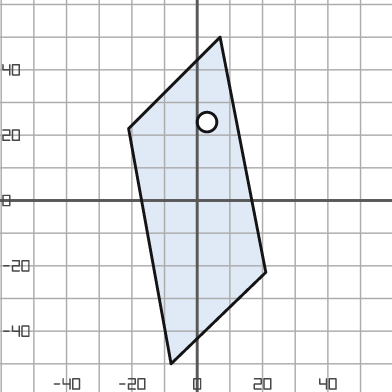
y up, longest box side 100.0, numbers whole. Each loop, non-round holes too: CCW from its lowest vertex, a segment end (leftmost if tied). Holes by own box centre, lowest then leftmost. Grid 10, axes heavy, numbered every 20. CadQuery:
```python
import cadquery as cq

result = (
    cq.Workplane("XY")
    .moveTo(-8.0, -50.0)
    .lineTo(21.0, -22.0)
    .lineTo(7.0, 50.0)
    .lineTo(-21.0, 22.0)
    .close()
    .moveTo(3.0, 24.0)
    .circle(3.0)
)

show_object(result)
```